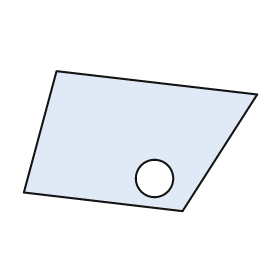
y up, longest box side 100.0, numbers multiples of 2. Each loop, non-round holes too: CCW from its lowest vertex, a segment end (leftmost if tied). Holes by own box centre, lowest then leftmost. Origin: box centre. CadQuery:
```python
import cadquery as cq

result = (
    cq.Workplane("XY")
    .moveTo(18.0, -30.0)
    .lineTo(50.0, 20.0)
    .lineTo(-36.0, 30.0)
    .lineTo(-50.0, -22.0)
    .close()
    .moveTo(6.0, -16.0)
    .circle(8.0)
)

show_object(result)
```